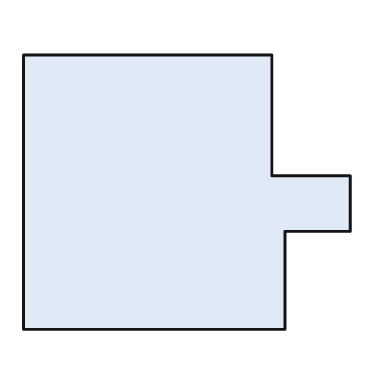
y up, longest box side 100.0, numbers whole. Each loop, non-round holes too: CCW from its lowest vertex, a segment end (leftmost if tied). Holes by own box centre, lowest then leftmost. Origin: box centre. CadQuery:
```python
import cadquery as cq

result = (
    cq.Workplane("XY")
    .moveTo(-50.0, -42.0)
    .lineTo(30.0, -42.0)
    .lineTo(30.0, -12.0)
    .lineTo(50.0, -12.0)
    .lineTo(50.0, 5.0)
    .lineTo(26.0, 5.0)
    .lineTo(26.0, 42.0)
    .lineTo(-50.0, 42.0)
    .close()
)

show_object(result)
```